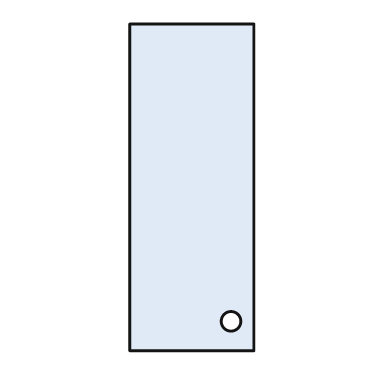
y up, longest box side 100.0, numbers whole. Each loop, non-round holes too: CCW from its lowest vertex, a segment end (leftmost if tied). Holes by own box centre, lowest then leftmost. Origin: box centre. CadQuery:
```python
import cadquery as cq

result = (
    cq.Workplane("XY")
    .moveTo(-19.0, -50.0)
    .lineTo(19.0, -50.0)
    .lineTo(19.0, 50.0)
    .lineTo(-19.0, 50.0)
    .close()
    .moveTo(12.0, -41.0)
    .circle(3.0)
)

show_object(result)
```